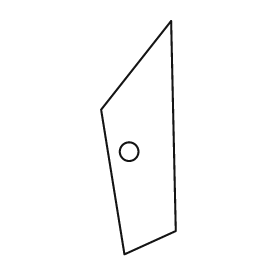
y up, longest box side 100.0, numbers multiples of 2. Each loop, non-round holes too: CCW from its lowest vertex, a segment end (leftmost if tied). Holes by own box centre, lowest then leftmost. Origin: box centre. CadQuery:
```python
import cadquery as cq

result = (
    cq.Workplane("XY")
    .moveTo(-6.0, -50.0)
    .lineTo(16.0, -40.0)
    .lineTo(14.0, 50.0)
    .lineTo(-16.0, 12.0)
    .close()
    .moveTo(-4.0, -6.0)
    .circle(4.0)
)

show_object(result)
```